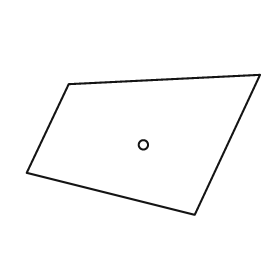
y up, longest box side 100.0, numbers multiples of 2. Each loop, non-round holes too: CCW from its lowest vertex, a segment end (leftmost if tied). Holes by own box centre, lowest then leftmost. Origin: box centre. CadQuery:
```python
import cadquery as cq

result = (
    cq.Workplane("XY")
    .moveTo(22.0, -30.0)
    .lineTo(50.0, 30.0)
    .lineTo(-32.0, 26.0)
    .lineTo(-50.0, -12.0)
    .close()
    .moveTo(0.0, 0.0)
    .circle(2.0)
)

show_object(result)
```